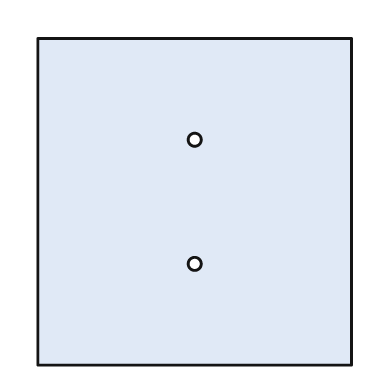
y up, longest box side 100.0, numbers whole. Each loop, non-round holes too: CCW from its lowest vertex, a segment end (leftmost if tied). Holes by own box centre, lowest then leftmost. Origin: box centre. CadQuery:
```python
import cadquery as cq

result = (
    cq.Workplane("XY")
    .moveTo(-48.0, -50.0)
    .lineTo(48.0, -50.0)
    .lineTo(48.0, 50.0)
    .lineTo(-48.0, 50.0)
    .close()
    .moveTo(0.0, -19.0)
    .circle(2.0)
    .moveTo(0.0, 19.0)
    .circle(2.0)
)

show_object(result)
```